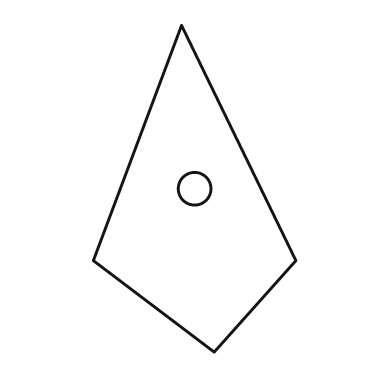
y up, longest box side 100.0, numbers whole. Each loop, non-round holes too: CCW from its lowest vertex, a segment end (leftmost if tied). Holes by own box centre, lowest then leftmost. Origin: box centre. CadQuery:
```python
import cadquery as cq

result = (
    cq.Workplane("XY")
    .moveTo(6.0, -50.0)
    .lineTo(31.0, -22.0)
    .lineTo(-4.0, 50.0)
    .lineTo(-31.0, -22.0)
    .close()
    .moveTo(0.0, 0.0)
    .circle(5.0)
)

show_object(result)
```